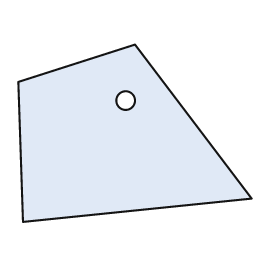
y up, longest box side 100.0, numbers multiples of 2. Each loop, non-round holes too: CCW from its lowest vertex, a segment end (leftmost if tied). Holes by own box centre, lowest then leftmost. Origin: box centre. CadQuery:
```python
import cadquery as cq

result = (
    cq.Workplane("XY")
    .moveTo(-48.0, -38.0)
    .lineTo(50.0, -28.0)
    .lineTo(0.0, 38.0)
    .lineTo(-50.0, 22.0)
    .close()
    .moveTo(-4.0, 14.0)
    .circle(4.0)
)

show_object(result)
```